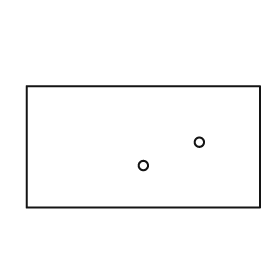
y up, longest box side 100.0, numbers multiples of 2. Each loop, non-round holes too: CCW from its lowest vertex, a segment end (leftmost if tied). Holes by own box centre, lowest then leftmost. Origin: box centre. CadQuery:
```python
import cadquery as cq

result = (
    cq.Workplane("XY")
    .moveTo(-50.0, -26.0)
    .lineTo(50.0, -26.0)
    .lineTo(50.0, 26.0)
    .lineTo(-50.0, 26.0)
    .close()
    .moveTo(0.0, -8.0)
    .circle(2.0)
    .moveTo(24.0, 2.0)
    .circle(2.0)
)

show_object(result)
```